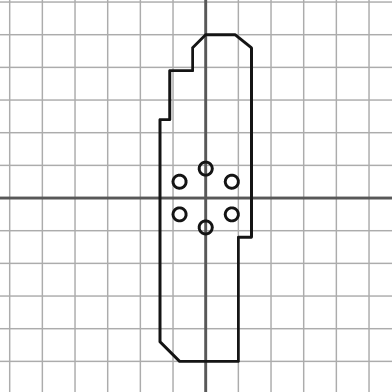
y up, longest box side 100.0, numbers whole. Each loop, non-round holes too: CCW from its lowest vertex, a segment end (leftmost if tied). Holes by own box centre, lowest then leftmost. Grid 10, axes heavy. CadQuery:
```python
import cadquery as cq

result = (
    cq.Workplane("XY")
    .moveTo(-8.0, -50.0)
    .lineTo(10.0, -50.0)
    .lineTo(10.0, -12.0)
    .lineTo(14.0, -12.0)
    .lineTo(14.0, 46.0)
    .lineTo(9.0, 50.0)
    .lineTo(0.0, 50.0)
    .lineTo(-4.0, 46.0)
    .lineTo(-4.0, 39.0)
    .lineTo(-11.0, 39.0)
    .lineTo(-11.0, 24.0)
    .lineTo(-14.0, 24.0)
    .lineTo(-14.0, -44.0)
    .close()
    .moveTo(0.0, -9.0)
    .circle(2.0)
    .moveTo(-8.0, -5.0)
    .circle(2.0)
    .moveTo(8.0, -5.0)
    .circle(2.0)
    .moveTo(-8.0, 5.0)
    .circle(2.0)
    .moveTo(8.0, 5.0)
    .circle(2.0)
    .moveTo(0.0, 9.0)
    .circle(2.0)
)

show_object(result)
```